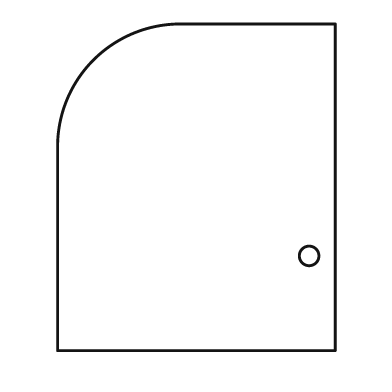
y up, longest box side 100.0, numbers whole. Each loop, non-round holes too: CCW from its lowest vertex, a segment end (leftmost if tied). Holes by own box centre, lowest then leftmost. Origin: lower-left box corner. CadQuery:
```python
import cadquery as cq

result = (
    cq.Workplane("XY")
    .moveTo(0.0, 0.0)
    .lineTo(85.0, 0.0)
    .lineTo(85.0, 100.0)
    .lineTo(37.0, 100.0)
    .threePointArc((11.0, 89.0), (0.0, 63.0))
    .close()
    .moveTo(77.0, 29.0)
    .circle(3.0)
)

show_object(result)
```